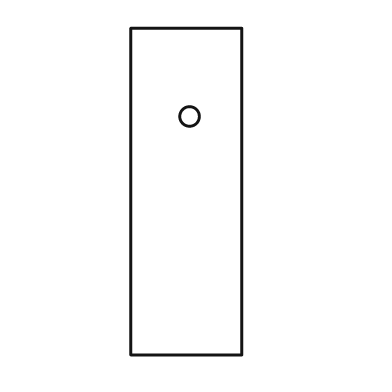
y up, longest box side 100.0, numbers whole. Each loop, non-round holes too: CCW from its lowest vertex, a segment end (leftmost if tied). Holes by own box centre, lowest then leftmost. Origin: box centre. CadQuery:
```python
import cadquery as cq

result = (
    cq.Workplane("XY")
    .moveTo(-17.0, -50.0)
    .lineTo(17.0, -50.0)
    .lineTo(17.0, 50.0)
    .lineTo(-17.0, 50.0)
    .close()
    .moveTo(1.0, 23.0)
    .circle(3.0)
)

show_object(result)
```